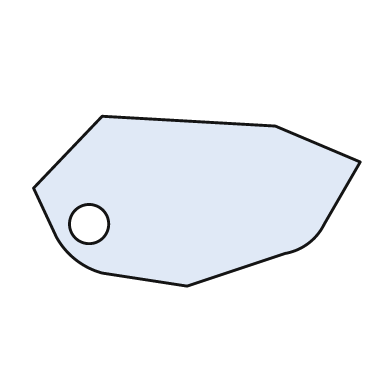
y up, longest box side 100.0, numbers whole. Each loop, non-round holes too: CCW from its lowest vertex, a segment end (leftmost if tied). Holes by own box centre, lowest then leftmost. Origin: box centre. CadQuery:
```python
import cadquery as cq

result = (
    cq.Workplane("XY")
    .moveTo(-3.0, -26.0)
    .lineTo(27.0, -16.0)
    .threePointArc((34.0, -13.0), (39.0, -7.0))
    .lineTo(50.0, 12.0)
    .lineTo(24.0, 23.0)
    .lineTo(-29.0, 26.0)
    .lineTo(-50.0, 4.0)
    .lineTo(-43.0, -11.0)
    .threePointArc((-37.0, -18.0), (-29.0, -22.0))
    .close()
    .moveTo(-33.0, -7.0)
    .circle(6.0)
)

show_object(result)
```